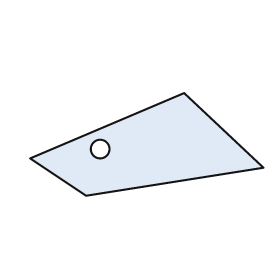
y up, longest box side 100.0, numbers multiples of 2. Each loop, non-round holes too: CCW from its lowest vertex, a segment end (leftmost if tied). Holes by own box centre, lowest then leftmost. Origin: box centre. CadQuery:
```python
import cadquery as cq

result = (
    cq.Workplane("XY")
    .moveTo(-26.0, -22.0)
    .lineTo(50.0, -10.0)
    .lineTo(16.0, 22.0)
    .lineTo(-50.0, -6.0)
    .close()
    .moveTo(-20.0, -2.0)
    .circle(4.0)
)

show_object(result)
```